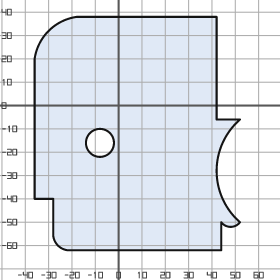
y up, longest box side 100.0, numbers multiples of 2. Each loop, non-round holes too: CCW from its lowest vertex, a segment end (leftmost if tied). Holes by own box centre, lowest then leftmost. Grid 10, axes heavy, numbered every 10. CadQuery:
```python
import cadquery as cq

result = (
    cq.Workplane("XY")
    .moveTo(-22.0, -62.0)
    .lineTo(44.0, -62.0)
    .lineTo(44.0, -50.0)
    .threePointArc((48.0, -52.0), (52.0, -50.0))
    .threePointArc((42.0, -28.0), (52.0, -6.0))
    .lineTo(42.0, -6.0)
    .lineTo(42.0, 38.0)
    .lineTo(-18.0, 38.0)
    .threePointArc((-30.0, 32.0), (-36.0, 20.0))
    .lineTo(-36.0, -40.0)
    .lineTo(-28.0, -40.0)
    .lineTo(-28.0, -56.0)
    .threePointArc((-26.0, -60.0), (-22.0, -62.0))
    .close()
    .moveTo(-8.0, -16.0)
    .circle(6.0)
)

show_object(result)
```